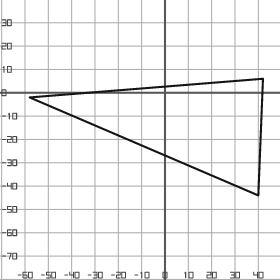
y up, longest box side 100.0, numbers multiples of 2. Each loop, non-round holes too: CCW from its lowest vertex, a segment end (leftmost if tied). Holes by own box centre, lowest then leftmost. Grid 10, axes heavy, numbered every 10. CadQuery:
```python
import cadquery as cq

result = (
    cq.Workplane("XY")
    .moveTo(40.0, -44.0)
    .lineTo(42.0, 6.0)
    .lineTo(-58.0, -2.0)
    .close()
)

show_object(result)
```